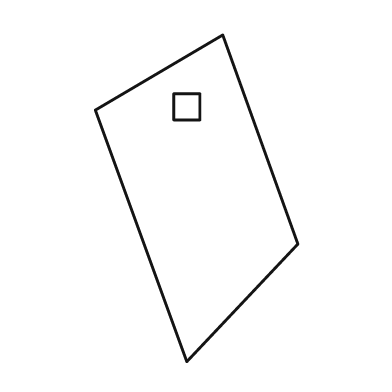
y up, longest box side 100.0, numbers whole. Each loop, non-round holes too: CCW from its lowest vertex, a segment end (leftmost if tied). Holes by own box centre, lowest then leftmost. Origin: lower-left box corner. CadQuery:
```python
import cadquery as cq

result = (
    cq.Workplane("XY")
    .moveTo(28.0, 0.0)
    .lineTo(62.0, 36.0)
    .lineTo(39.0, 100.0)
    .lineTo(0.0, 77.0)
    .close()
    .moveTo(24.0, 74.0)
    .lineTo(32.0, 74.0)
    .lineTo(32.0, 82.0)
    .lineTo(24.0, 82.0)
    .close()
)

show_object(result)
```